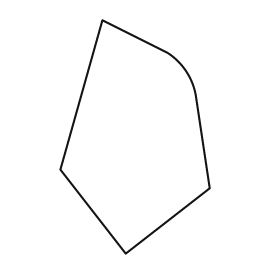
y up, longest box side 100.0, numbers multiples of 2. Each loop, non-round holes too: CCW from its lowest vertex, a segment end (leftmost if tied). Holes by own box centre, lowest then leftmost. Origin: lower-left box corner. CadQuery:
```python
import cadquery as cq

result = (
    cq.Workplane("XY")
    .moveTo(28.0, 0.0)
    .lineTo(64.0, 28.0)
    .lineTo(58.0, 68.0)
    .threePointArc((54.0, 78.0), (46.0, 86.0))
    .lineTo(18.0, 100.0)
    .lineTo(0.0, 36.0)
    .close()
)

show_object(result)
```